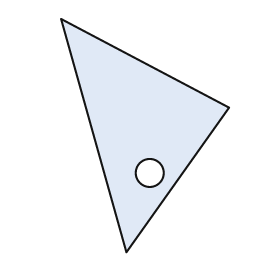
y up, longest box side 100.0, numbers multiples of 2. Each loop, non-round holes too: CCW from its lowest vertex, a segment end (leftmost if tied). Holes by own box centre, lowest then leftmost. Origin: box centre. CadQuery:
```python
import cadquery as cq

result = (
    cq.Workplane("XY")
    .moveTo(-8.0, -50.0)
    .lineTo(36.0, 12.0)
    .lineTo(-36.0, 50.0)
    .close()
    .moveTo(2.0, -16.0)
    .circle(6.0)
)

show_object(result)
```